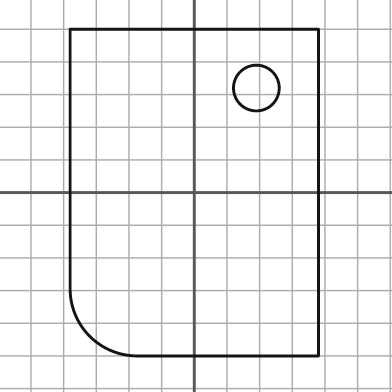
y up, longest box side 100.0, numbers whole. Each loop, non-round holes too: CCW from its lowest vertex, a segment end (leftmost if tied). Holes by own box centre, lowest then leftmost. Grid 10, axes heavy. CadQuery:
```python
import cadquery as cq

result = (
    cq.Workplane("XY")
    .moveTo(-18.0, -50.0)
    .lineTo(38.0, -50.0)
    .lineTo(38.0, 50.0)
    .lineTo(-38.0, 50.0)
    .lineTo(-38.0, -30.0)
    .threePointArc((-32.0, -44.0), (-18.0, -50.0))
    .close()
    .moveTo(19.0, 32.0)
    .circle(7.0)
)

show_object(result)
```